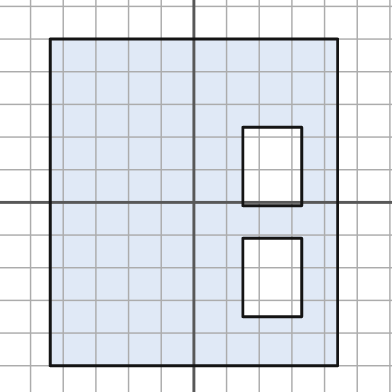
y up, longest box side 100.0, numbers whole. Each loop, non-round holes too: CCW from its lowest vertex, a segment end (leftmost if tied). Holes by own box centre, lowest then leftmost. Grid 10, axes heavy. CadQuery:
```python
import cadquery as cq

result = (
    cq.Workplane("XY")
    .moveTo(-44.0, -50.0)
    .lineTo(44.0, -50.0)
    .lineTo(44.0, 50.0)
    .lineTo(-44.0, 50.0)
    .close()
    .moveTo(15.0, -35.0)
    .lineTo(33.0, -35.0)
    .lineTo(33.0, -11.0)
    .lineTo(15.0, -11.0)
    .close()
    .moveTo(15.0, -1.0)
    .lineTo(33.0, -1.0)
    .lineTo(33.0, 23.0)
    .lineTo(15.0, 23.0)
    .close()
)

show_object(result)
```